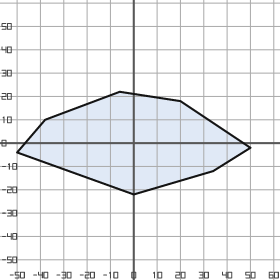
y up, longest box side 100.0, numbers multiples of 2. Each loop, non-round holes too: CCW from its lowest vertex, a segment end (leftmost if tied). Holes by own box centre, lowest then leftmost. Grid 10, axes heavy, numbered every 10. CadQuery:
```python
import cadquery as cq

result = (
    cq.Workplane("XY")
    .moveTo(0.0, -22.0)
    .lineTo(34.0, -12.0)
    .lineTo(50.0, -2.0)
    .lineTo(20.0, 18.0)
    .lineTo(-6.0, 22.0)
    .lineTo(-38.0, 10.0)
    .lineTo(-50.0, -4.0)
    .close()
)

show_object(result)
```